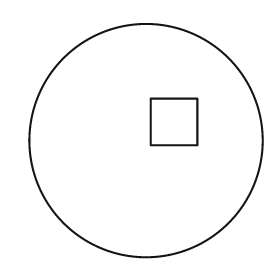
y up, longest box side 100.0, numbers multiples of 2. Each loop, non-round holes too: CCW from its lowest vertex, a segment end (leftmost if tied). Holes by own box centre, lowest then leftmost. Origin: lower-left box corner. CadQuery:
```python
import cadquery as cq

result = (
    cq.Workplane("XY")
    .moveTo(50.0, 50.0)
    .circle(50.0)
    .moveTo(52.0, 48.0)
    .lineTo(72.0, 48.0)
    .lineTo(72.0, 68.0)
    .lineTo(52.0, 68.0)
    .close()
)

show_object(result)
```